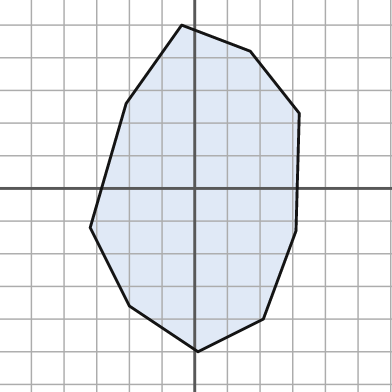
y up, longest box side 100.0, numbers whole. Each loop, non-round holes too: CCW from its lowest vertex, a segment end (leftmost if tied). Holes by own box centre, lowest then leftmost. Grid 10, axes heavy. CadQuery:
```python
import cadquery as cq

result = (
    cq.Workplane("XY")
    .moveTo(1.0, -50.0)
    .lineTo(21.0, -40.0)
    .lineTo(31.0, -13.0)
    .lineTo(32.0, 23.0)
    .lineTo(17.0, 42.0)
    .lineTo(-4.0, 50.0)
    .lineTo(-21.0, 26.0)
    .lineTo(-32.0, -12.0)
    .lineTo(-20.0, -36.0)
    .close()
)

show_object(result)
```